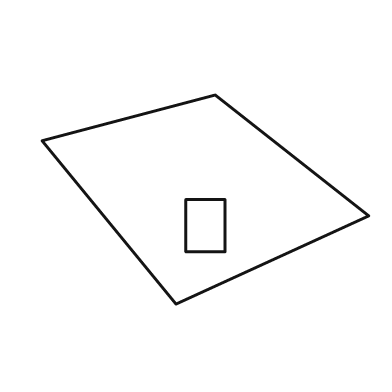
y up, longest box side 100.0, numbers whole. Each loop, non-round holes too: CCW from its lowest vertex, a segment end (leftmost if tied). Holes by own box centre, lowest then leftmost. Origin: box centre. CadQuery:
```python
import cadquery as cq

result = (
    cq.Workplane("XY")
    .moveTo(-9.0, -32.0)
    .lineTo(50.0, -5.0)
    .lineTo(3.0, 32.0)
    .lineTo(-50.0, 18.0)
    .close()
    .moveTo(-6.0, -16.0)
    .lineTo(6.0, -16.0)
    .lineTo(6.0, 0.0)
    .lineTo(-6.0, 0.0)
    .close()
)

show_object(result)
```